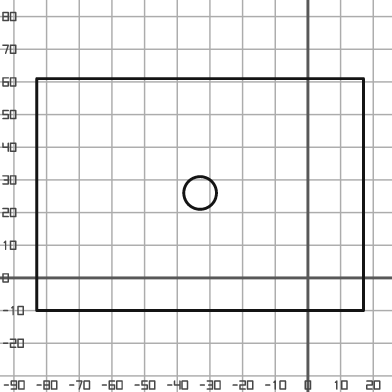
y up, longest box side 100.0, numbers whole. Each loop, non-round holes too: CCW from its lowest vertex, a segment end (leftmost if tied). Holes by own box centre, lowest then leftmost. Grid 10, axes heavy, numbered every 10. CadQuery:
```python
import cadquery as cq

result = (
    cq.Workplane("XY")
    .moveTo(-83.0, -10.0)
    .lineTo(17.0, -10.0)
    .lineTo(17.0, 61.0)
    .lineTo(-83.0, 61.0)
    .close()
    .moveTo(-33.0, 26.0)
    .circle(5.0)
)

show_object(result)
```